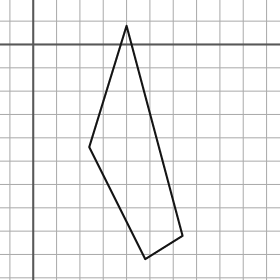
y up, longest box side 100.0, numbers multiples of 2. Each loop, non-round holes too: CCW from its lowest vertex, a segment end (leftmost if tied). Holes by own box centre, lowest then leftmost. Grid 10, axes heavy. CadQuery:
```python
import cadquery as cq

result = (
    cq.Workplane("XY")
    .moveTo(48.0, -92.0)
    .lineTo(64.0, -82.0)
    .lineTo(40.0, 8.0)
    .lineTo(24.0, -44.0)
    .close()
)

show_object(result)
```